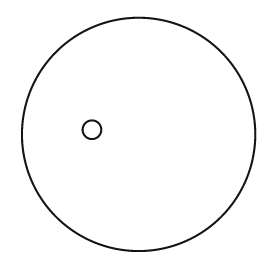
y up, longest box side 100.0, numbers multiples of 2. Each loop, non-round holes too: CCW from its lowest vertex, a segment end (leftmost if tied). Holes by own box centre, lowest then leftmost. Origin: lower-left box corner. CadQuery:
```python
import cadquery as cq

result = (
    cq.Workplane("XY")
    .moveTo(50.0, 50.0)
    .circle(50.0)
    .moveTo(30.0, 52.0)
    .circle(4.0)
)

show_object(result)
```